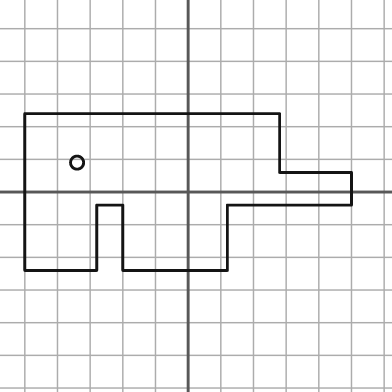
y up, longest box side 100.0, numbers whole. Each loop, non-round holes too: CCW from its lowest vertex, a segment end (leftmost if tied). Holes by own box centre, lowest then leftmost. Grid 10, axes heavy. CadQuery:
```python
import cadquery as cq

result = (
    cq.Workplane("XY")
    .moveTo(-50.0, -24.0)
    .lineTo(-28.0, -24.0)
    .lineTo(-28.0, -4.0)
    .lineTo(-20.0, -4.0)
    .lineTo(-20.0, -24.0)
    .lineTo(12.0, -24.0)
    .lineTo(12.0, -4.0)
    .lineTo(50.0, -4.0)
    .lineTo(50.0, 6.0)
    .lineTo(28.0, 6.0)
    .lineTo(28.0, 24.0)
    .lineTo(-50.0, 24.0)
    .close()
    .moveTo(-34.0, 9.0)
    .circle(2.0)
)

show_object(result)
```